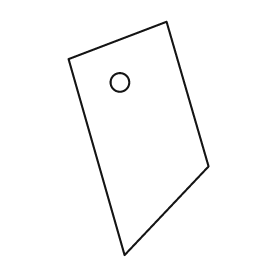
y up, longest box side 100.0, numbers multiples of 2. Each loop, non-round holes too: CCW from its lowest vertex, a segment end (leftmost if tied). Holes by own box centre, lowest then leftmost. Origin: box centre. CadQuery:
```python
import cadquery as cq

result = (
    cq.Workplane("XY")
    .moveTo(-6.0, -50.0)
    .lineTo(30.0, -12.0)
    .lineTo(12.0, 50.0)
    .lineTo(-30.0, 34.0)
    .close()
    .moveTo(-8.0, 24.0)
    .circle(4.0)
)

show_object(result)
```